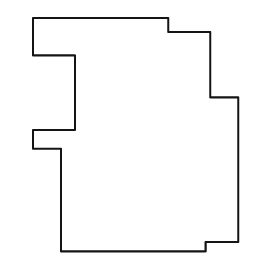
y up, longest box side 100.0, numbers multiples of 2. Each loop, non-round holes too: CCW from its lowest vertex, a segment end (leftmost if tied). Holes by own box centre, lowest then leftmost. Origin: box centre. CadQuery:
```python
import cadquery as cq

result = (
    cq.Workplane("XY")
    .moveTo(-32.0, -50.0)
    .lineTo(30.0, -50.0)
    .lineTo(30.0, -46.0)
    .lineTo(44.0, -46.0)
    .lineTo(44.0, 16.0)
    .lineTo(32.0, 16.0)
    .lineTo(32.0, 44.0)
    .lineTo(14.0, 44.0)
    .lineTo(14.0, 50.0)
    .lineTo(-44.0, 50.0)
    .lineTo(-44.0, 34.0)
    .lineTo(-26.0, 34.0)
    .lineTo(-26.0, 2.0)
    .lineTo(-44.0, 2.0)
    .lineTo(-44.0, -6.0)
    .lineTo(-32.0, -6.0)
    .close()
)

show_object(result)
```